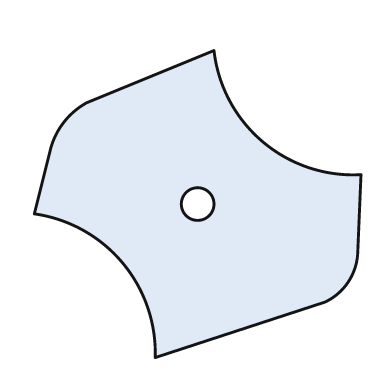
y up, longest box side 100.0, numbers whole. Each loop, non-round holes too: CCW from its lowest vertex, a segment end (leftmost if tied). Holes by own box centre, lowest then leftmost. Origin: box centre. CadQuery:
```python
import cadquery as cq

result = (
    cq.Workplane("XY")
    .moveTo(-13.0, -47.0)
    .lineTo(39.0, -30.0)
    .threePointArc((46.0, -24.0), (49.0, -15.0))
    .lineTo(50.0, 9.0)
    .threePointArc((20.0, 19.0), (5.0, 47.0))
    .lineTo(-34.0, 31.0)
    .threePointArc((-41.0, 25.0), (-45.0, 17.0))
    .lineTo(-50.0, -3.0)
    .threePointArc((-23.0, -18.0), (-13.0, -47.0))
    .close()
    .moveTo(0.0, 0.0)
    .circle(5.0)
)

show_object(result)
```